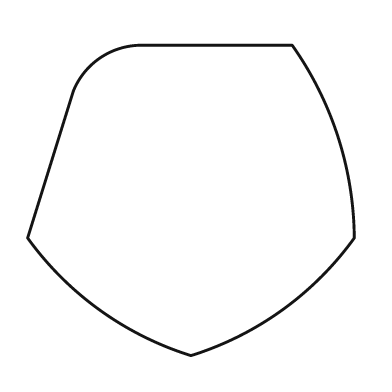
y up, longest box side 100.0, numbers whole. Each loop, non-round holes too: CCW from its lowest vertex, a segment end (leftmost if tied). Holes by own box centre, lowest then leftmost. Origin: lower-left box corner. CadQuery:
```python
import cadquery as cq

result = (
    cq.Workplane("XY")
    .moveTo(50.0, 0.0)
    .threePointArc((78.0, 14.0), (100.0, 36.0))
    .threePointArc((95.0, 67.0), (81.0, 95.0))
    .lineTo(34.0, 95.0)
    .threePointArc((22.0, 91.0), (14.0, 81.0))
    .lineTo(0.0, 36.0)
    .threePointArc((22.0, 14.0), (50.0, 0.0))
    .close()
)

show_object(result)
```